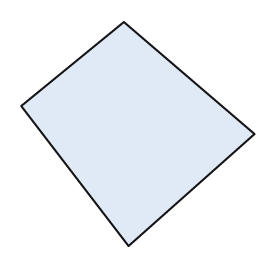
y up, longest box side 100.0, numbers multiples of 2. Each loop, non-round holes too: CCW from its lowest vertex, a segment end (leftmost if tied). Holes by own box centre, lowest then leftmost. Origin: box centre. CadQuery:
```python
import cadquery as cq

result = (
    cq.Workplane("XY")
    .moveTo(-4.0, -48.0)
    .lineTo(50.0, 0.0)
    .lineTo(-6.0, 48.0)
    .lineTo(-50.0, 12.0)
    .close()
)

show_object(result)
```